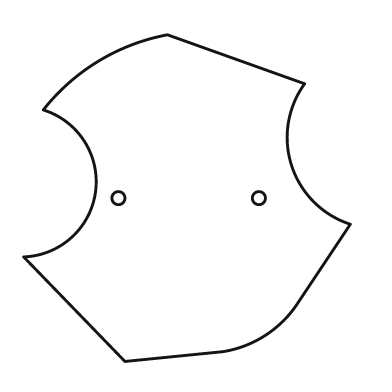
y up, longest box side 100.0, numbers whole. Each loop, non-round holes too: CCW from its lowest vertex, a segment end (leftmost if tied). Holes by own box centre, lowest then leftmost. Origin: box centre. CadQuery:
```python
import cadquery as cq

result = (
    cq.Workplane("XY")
    .moveTo(-19.0, -50.0)
    .lineTo(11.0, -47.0)
    .threePointArc((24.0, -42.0), (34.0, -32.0))
    .lineTo(50.0, -8.0)
    .threePointArc((32.0, 10.0), (36.0, 35.0))
    .lineTo(-6.0, 50.0)
    .threePointArc((-27.0, 42.0), (-44.0, 27.0))
    .threePointArc((-28.0, 2.0), (-50.0, -18.0))
    .close()
    .moveTo(-21.0, 0.0)
    .circle(2.0)
    .moveTo(22.0, 0.0)
    .circle(2.0)
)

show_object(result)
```